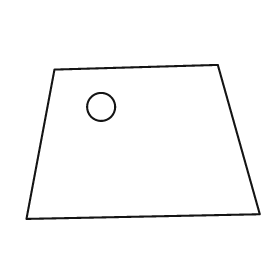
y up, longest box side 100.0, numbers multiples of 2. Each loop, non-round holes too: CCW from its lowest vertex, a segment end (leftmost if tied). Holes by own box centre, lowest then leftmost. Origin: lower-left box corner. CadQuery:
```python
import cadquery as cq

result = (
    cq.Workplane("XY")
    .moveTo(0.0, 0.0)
    .lineTo(100.0, 2.0)
    .lineTo(82.0, 66.0)
    .lineTo(12.0, 64.0)
    .close()
    .moveTo(32.0, 48.0)
    .circle(6.0)
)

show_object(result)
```